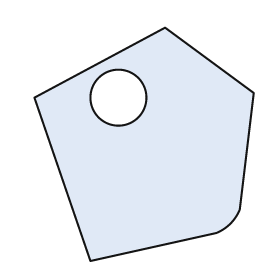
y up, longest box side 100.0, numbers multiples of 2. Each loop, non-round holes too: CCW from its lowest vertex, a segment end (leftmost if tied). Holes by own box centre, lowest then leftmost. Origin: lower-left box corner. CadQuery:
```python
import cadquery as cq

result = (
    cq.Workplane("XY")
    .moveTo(24.0, 0.0)
    .lineTo(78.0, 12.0)
    .threePointArc((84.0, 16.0), (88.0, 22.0))
    .lineTo(94.0, 72.0)
    .lineTo(56.0, 100.0)
    .lineTo(0.0, 70.0)
    .close()
    .moveTo(36.0, 70.0)
    .circle(12.0)
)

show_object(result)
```